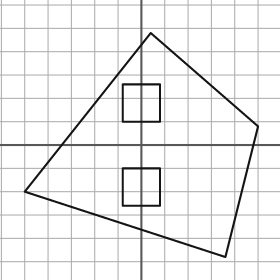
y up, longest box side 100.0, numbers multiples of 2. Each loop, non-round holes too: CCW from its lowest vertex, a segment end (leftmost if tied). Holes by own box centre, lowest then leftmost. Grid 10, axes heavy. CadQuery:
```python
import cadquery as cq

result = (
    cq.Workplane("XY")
    .moveTo(36.0, -48.0)
    .lineTo(50.0, 8.0)
    .lineTo(4.0, 48.0)
    .lineTo(-50.0, -20.0)
    .close()
    .moveTo(-8.0, -26.0)
    .lineTo(8.0, -26.0)
    .lineTo(8.0, -10.0)
    .lineTo(-8.0, -10.0)
    .close()
    .moveTo(-8.0, 10.0)
    .lineTo(8.0, 10.0)
    .lineTo(8.0, 26.0)
    .lineTo(-8.0, 26.0)
    .close()
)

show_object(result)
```